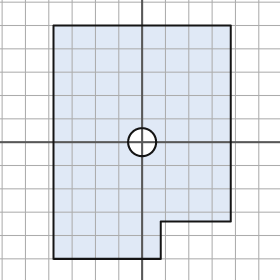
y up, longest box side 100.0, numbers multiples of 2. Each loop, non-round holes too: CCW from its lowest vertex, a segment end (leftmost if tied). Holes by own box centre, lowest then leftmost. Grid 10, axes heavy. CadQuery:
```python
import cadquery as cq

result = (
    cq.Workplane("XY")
    .moveTo(-38.0, -50.0)
    .lineTo(8.0, -50.0)
    .lineTo(8.0, -34.0)
    .lineTo(38.0, -34.0)
    .lineTo(38.0, 50.0)
    .lineTo(-38.0, 50.0)
    .close()
    .moveTo(0.0, 0.0)
    .circle(6.0)
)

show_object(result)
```